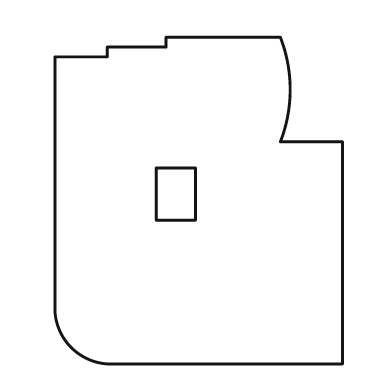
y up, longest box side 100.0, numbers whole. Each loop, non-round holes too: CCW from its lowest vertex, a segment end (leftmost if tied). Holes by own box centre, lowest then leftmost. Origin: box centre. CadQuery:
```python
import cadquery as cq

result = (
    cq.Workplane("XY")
    .moveTo(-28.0, -50.0)
    .lineTo(44.0, -50.0)
    .lineTo(44.0, 18.0)
    .lineTo(25.0, 18.0)
    .threePointArc((28.0, 34.0), (25.0, 50.0))
    .lineTo(-10.0, 50.0)
    .lineTo(-10.0, 47.0)
    .lineTo(-28.0, 47.0)
    .lineTo(-28.0, 44.0)
    .lineTo(-44.0, 44.0)
    .lineTo(-44.0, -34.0)
    .threePointArc((-39.0, -45.0), (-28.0, -50.0))
    .close()
    .moveTo(-13.0, -6.0)
    .lineTo(-1.0, -6.0)
    .lineTo(-1.0, 10.0)
    .lineTo(-13.0, 10.0)
    .close()
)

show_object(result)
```